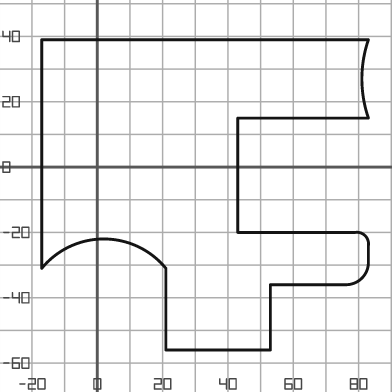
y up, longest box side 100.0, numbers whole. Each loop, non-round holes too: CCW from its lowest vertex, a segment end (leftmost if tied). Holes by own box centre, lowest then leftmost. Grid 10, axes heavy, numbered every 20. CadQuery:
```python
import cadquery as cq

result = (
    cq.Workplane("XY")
    .moveTo(21.0, -56.0)
    .lineTo(53.0, -56.0)
    .lineTo(53.0, -36.0)
    .lineTo(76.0, -36.0)
    .threePointArc((81.0, -34.0), (83.0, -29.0))
    .lineTo(83.0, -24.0)
    .threePointArc((82.0, -21.0), (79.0, -20.0))
    .lineTo(43.0, -20.0)
    .lineTo(43.0, 15.0)
    .lineTo(83.0, 15.0)
    .threePointArc((81.0, 27.0), (83.0, 39.0))
    .lineTo(-17.0, 39.0)
    .lineTo(-17.0, -31.0)
    .threePointArc((2.0, -22.0), (21.0, -31.0))
    .close()
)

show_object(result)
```